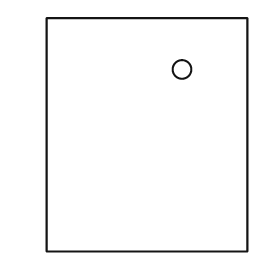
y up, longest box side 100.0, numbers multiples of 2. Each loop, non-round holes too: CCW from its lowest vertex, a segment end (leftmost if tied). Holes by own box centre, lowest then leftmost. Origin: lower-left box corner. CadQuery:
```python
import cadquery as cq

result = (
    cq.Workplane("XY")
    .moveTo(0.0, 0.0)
    .lineTo(86.0, 0.0)
    .lineTo(86.0, 100.0)
    .lineTo(0.0, 100.0)
    .close()
    .moveTo(58.0, 78.0)
    .circle(4.0)
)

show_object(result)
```